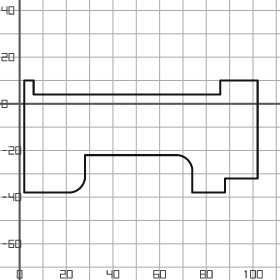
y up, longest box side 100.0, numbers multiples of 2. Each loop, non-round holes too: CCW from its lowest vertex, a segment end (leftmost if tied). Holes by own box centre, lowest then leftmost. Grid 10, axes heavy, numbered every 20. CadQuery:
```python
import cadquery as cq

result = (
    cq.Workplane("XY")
    .moveTo(2.0, -38.0)
    .lineTo(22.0, -38.0)
    .threePointArc((26.0, -36.0), (28.0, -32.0))
    .lineTo(28.0, -22.0)
    .lineTo(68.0, -22.0)
    .threePointArc((72.0, -24.0), (74.0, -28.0))
    .lineTo(74.0, -38.0)
    .lineTo(88.0, -38.0)
    .lineTo(88.0, -32.0)
    .lineTo(102.0, -32.0)
    .lineTo(102.0, 10.0)
    .lineTo(86.0, 10.0)
    .lineTo(86.0, 4.0)
    .lineTo(6.0, 4.0)
    .lineTo(6.0, 10.0)
    .lineTo(2.0, 10.0)
    .close()
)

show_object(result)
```